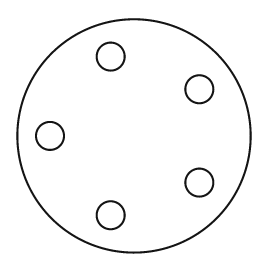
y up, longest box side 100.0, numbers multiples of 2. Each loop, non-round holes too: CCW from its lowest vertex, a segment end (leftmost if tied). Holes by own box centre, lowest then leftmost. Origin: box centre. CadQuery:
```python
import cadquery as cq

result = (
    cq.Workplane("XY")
    .moveTo(0.0, 0.0)
    .circle(50.0)
    .moveTo(-10.0, -34.0)
    .circle(6.0)
    .moveTo(28.0, -20.0)
    .circle(6.0)
    .moveTo(-36.0, 0.0)
    .circle(6.0)
    .moveTo(28.0, 20.0)
    .circle(6.0)
    .moveTo(-10.0, 34.0)
    .circle(6.0)
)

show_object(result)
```